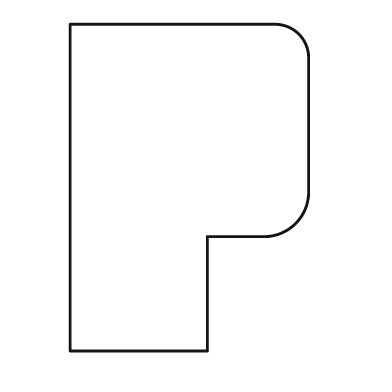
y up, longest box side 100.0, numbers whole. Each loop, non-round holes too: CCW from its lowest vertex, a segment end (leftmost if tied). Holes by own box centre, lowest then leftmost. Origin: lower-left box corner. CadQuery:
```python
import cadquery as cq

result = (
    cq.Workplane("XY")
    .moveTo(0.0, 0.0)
    .lineTo(42.0, 0.0)
    .lineTo(42.0, 35.0)
    .lineTo(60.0, 35.0)
    .threePointArc((69.0, 39.0), (73.0, 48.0))
    .lineTo(73.0, 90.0)
    .threePointArc((70.0, 97.0), (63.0, 100.0))
    .lineTo(0.0, 100.0)
    .close()
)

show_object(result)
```